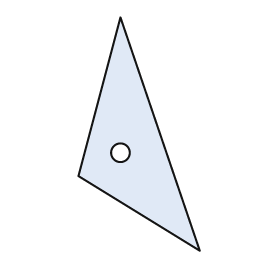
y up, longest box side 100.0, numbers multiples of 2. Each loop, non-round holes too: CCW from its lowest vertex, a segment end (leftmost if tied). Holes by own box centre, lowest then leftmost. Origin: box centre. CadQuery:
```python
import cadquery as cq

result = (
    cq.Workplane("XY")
    .moveTo(26.0, -50.0)
    .lineTo(-8.0, 50.0)
    .lineTo(-26.0, -18.0)
    .close()
    .moveTo(-8.0, -8.0)
    .circle(4.0)
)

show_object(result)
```